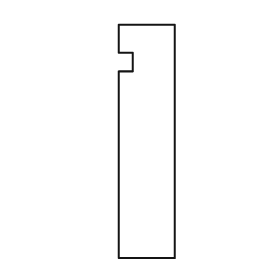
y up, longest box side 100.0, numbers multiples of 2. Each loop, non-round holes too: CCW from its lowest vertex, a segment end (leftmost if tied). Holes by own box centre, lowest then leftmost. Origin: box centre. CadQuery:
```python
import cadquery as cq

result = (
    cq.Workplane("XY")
    .moveTo(-12.0, -50.0)
    .lineTo(12.0, -50.0)
    .lineTo(12.0, 50.0)
    .lineTo(-12.0, 50.0)
    .lineTo(-12.0, 38.0)
    .lineTo(-6.0, 38.0)
    .lineTo(-6.0, 30.0)
    .lineTo(-12.0, 30.0)
    .close()
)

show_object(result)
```